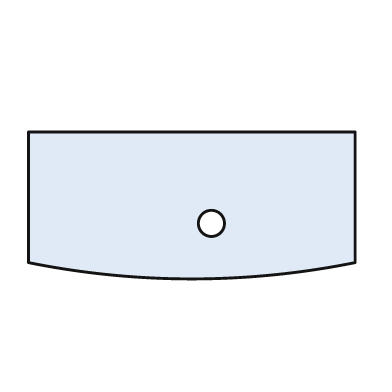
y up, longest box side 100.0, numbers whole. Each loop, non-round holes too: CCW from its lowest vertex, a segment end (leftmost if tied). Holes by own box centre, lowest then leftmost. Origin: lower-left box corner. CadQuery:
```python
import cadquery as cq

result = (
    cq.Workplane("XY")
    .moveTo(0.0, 5.0)
    .threePointArc((50.0, 0.0), (100.0, 5.0))
    .lineTo(100.0, 45.0)
    .lineTo(0.0, 45.0)
    .close()
    .moveTo(56.0, 17.0)
    .circle(4.0)
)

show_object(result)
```